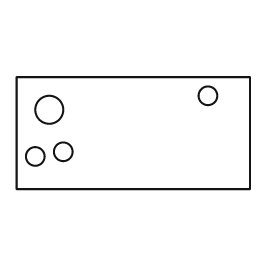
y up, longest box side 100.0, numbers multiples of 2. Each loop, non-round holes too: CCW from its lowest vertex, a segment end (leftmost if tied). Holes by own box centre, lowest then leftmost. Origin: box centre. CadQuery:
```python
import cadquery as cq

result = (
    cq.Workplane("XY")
    .moveTo(-50.0, -24.0)
    .lineTo(50.0, -24.0)
    .lineTo(50.0, 24.0)
    .lineTo(-50.0, 24.0)
    .close()
    .moveTo(-42.0, -10.0)
    .circle(4.0)
    .moveTo(-30.0, -8.0)
    .circle(4.0)
    .moveTo(-36.0, 10.0)
    .circle(6.0)
    .moveTo(32.0, 16.0)
    .circle(4.0)
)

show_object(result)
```